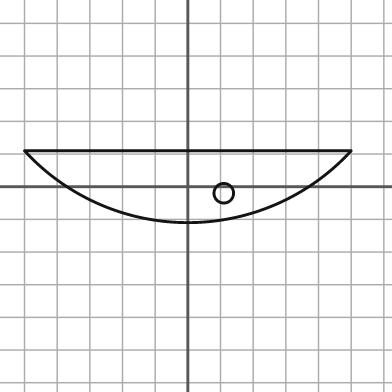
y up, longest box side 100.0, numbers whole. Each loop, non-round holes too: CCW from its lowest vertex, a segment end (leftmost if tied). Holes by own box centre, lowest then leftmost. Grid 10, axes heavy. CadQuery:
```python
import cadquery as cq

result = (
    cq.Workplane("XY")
    .moveTo(-50.0, 11.0)
    .threePointArc((0.0, -11.0), (50.0, 11.0))
    .close()
    .moveTo(11.0, -2.0)
    .circle(3.0)
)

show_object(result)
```